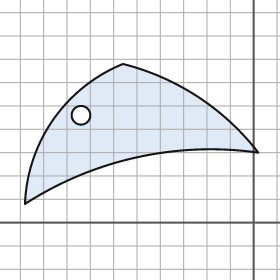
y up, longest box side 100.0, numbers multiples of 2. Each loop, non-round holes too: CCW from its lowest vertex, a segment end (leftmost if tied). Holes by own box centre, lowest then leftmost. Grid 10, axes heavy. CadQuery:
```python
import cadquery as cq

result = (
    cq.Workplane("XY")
    .moveTo(-98.0, 8.0)
    .threePointArc((-50.0, 28.0), (2.0, 30.0))
    .threePointArc((-24.0, 54.0), (-56.0, 68.0))
    .threePointArc((-86.0, 44.0), (-98.0, 8.0))
    .close()
    .moveTo(-74.0, 46.0)
    .circle(4.0)
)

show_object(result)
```